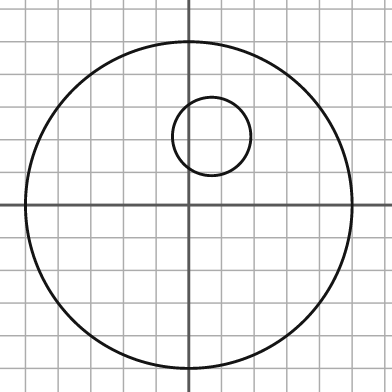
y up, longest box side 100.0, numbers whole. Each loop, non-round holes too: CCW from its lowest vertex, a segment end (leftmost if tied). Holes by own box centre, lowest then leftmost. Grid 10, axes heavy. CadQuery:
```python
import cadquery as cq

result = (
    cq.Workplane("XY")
    .moveTo(0.0, 0.0)
    .circle(50.0)
    .moveTo(7.0, 21.0)
    .circle(12.0)
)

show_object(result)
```